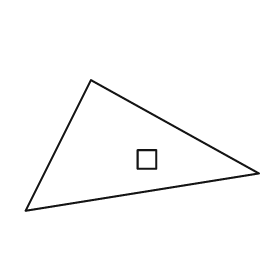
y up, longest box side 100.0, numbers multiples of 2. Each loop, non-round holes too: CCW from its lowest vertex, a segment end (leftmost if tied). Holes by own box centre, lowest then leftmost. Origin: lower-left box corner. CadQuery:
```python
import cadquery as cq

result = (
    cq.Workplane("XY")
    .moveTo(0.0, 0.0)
    .lineTo(100.0, 16.0)
    .lineTo(28.0, 56.0)
    .close()
    .moveTo(48.0, 18.0)
    .lineTo(56.0, 18.0)
    .lineTo(56.0, 26.0)
    .lineTo(48.0, 26.0)
    .close()
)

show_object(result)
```